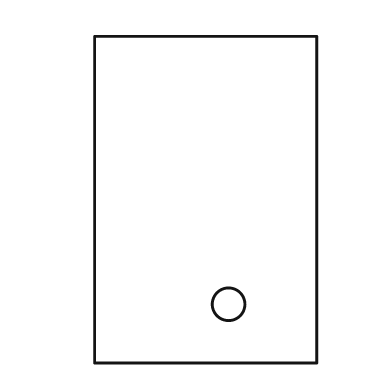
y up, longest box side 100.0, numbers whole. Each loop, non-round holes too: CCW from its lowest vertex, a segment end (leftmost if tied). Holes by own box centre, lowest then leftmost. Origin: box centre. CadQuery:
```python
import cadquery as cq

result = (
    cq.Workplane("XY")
    .moveTo(-34.0, -50.0)
    .lineTo(34.0, -50.0)
    .lineTo(34.0, 50.0)
    .lineTo(-34.0, 50.0)
    .close()
    .moveTo(7.0, -32.0)
    .circle(5.0)
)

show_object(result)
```